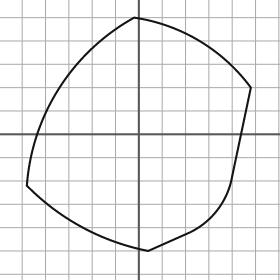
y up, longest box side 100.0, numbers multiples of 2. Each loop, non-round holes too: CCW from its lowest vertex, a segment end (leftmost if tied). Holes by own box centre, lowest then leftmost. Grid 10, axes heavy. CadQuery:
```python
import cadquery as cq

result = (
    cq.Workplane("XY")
    .moveTo(4.0, -50.0)
    .lineTo(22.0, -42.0)
    .threePointArc((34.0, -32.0), (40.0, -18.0))
    .lineTo(48.0, 20.0)
    .threePointArc((26.0, 40.0), (-2.0, 50.0))
    .threePointArc((-34.0, 20.0), (-48.0, -22.0))
    .threePointArc((-24.0, -40.0), (4.0, -50.0))
    .close()
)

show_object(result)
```